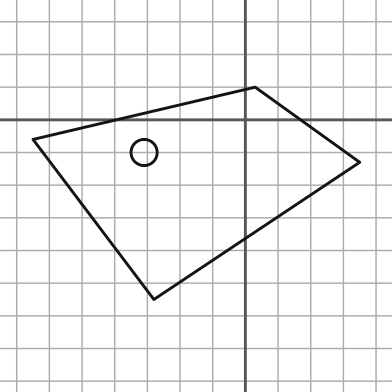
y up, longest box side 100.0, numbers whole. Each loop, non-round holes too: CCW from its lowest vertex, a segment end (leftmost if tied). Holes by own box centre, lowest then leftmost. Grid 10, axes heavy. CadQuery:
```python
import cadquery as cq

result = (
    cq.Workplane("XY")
    .moveTo(-28.0, -55.0)
    .lineTo(35.0, -13.0)
    .lineTo(3.0, 10.0)
    .lineTo(-65.0, -6.0)
    .close()
    .moveTo(-31.0, -10.0)
    .circle(4.0)
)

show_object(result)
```